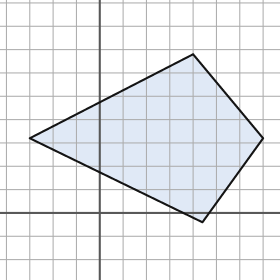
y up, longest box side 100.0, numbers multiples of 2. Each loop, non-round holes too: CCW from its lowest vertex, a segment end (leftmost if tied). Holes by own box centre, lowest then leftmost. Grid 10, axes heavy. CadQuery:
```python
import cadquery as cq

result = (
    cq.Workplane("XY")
    .moveTo(44.0, -4.0)
    .lineTo(70.0, 32.0)
    .lineTo(40.0, 68.0)
    .lineTo(-30.0, 32.0)
    .close()
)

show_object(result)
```